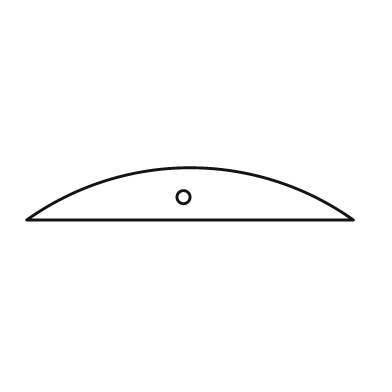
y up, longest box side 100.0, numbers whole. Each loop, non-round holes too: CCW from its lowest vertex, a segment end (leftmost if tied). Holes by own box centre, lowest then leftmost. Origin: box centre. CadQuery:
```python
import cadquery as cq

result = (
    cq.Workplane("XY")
    .moveTo(-50.0, -8.0)
    .lineTo(50.0, -8.0)
    .threePointArc((0.0, 8.0), (-50.0, -8.0))
    .close()
    .moveTo(-2.0, -1.0)
    .circle(2.0)
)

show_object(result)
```